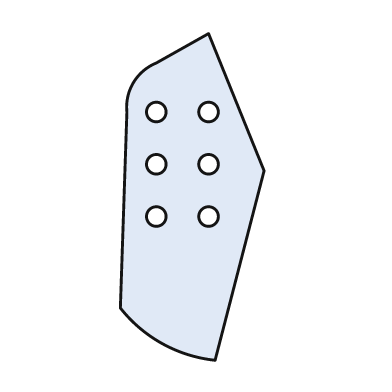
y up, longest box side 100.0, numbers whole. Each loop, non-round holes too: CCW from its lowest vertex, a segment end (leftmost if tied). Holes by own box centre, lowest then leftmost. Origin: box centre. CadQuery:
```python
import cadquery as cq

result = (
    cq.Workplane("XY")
    .moveTo(7.0, -50.0)
    .lineTo(22.0, 8.0)
    .lineTo(5.0, 50.0)
    .lineTo(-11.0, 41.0)
    .threePointArc((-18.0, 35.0), (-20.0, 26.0))
    .lineTo(-22.0, -34.0)
    .threePointArc((-9.0, -45.0), (7.0, -50.0))
    .close()
    .moveTo(-11.0, -6.0)
    .circle(3.0)
    .moveTo(5.0, -6.0)
    .circle(3.0)
    .moveTo(-11.0, 10.0)
    .circle(3.0)
    .moveTo(5.0, 10.0)
    .circle(3.0)
    .moveTo(-11.0, 26.0)
    .circle(3.0)
    .moveTo(5.0, 26.0)
    .circle(3.0)
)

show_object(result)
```